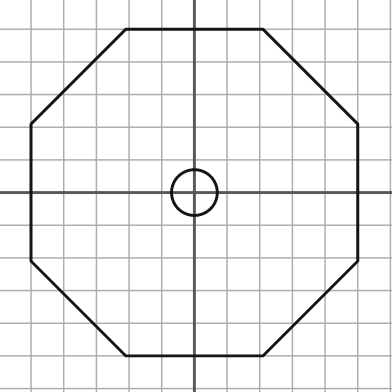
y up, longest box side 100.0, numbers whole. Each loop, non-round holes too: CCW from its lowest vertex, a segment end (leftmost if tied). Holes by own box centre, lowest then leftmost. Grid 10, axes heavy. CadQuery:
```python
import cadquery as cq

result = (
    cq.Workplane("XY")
    .moveTo(-21.0, -50.0)
    .lineTo(21.0, -50.0)
    .lineTo(50.0, -21.0)
    .lineTo(50.0, 21.0)
    .lineTo(21.0, 50.0)
    .lineTo(-21.0, 50.0)
    .lineTo(-50.0, 21.0)
    .lineTo(-50.0, -21.0)
    .close()
    .moveTo(0.0, 0.0)
    .circle(7.0)
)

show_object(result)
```